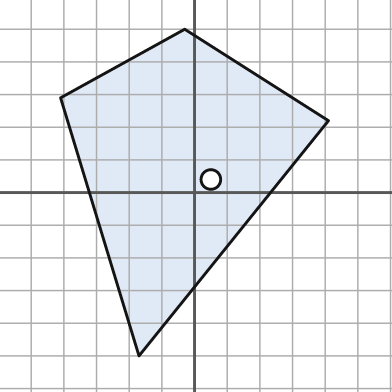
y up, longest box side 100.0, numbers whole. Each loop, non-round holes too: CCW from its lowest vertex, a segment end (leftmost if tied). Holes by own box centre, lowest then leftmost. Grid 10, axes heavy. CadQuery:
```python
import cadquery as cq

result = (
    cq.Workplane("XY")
    .moveTo(-17.0, -50.0)
    .lineTo(41.0, 22.0)
    .lineTo(-3.0, 50.0)
    .lineTo(-41.0, 29.0)
    .close()
    .moveTo(5.0, 4.0)
    .circle(3.0)
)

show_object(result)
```